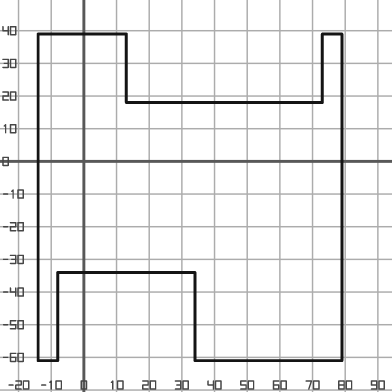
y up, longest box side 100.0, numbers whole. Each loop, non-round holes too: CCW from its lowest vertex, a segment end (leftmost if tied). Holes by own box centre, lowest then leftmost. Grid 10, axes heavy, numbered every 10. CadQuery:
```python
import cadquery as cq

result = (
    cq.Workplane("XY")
    .moveTo(-14.0, -61.0)
    .lineTo(-8.0, -61.0)
    .lineTo(-8.0, -34.0)
    .lineTo(34.0, -34.0)
    .lineTo(34.0, -61.0)
    .lineTo(79.0, -61.0)
    .lineTo(79.0, 39.0)
    .lineTo(73.0, 39.0)
    .lineTo(73.0, 18.0)
    .lineTo(13.0, 18.0)
    .lineTo(13.0, 39.0)
    .lineTo(-14.0, 39.0)
    .close()
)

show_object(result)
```